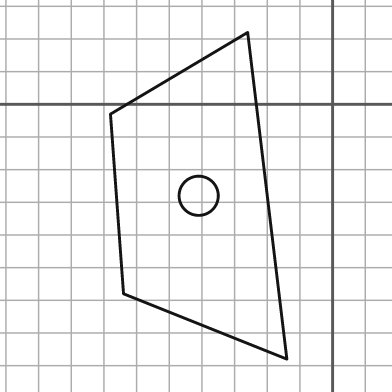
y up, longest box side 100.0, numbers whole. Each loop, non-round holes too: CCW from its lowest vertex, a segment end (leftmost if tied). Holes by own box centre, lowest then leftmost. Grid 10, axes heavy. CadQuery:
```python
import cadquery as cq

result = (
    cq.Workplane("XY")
    .moveTo(-14.0, -78.0)
    .lineTo(-26.0, 22.0)
    .lineTo(-68.0, -3.0)
    .lineTo(-64.0, -58.0)
    .close()
    .moveTo(-41.0, -28.0)
    .circle(6.0)
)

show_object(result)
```